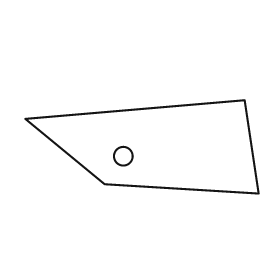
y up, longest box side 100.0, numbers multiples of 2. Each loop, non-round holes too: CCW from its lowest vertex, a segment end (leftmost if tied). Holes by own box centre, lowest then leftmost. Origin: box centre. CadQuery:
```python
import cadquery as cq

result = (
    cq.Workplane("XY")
    .moveTo(50.0, -20.0)
    .lineTo(44.0, 20.0)
    .lineTo(-50.0, 12.0)
    .lineTo(-16.0, -16.0)
    .close()
    .moveTo(-8.0, -4.0)
    .circle(4.0)
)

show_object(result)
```